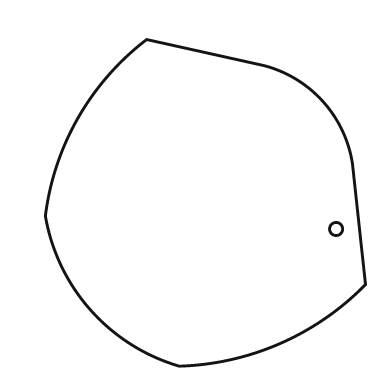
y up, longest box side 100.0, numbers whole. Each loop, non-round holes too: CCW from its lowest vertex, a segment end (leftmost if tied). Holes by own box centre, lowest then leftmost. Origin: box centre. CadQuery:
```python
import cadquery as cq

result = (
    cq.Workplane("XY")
    .moveTo(-8.0, -50.0)
    .threePointArc((23.0, -43.0), (49.0, -25.0))
    .lineTo(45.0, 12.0)
    .threePointArc((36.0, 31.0), (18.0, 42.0))
    .lineTo(-18.0, 50.0)
    .threePointArc((-39.0, 26.0), (-49.0, -4.0))
    .threePointArc((-35.0, -33.0), (-8.0, -50.0))
    .close()
    .moveTo(40.0, -8.0)
    .circle(2.0)
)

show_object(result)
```